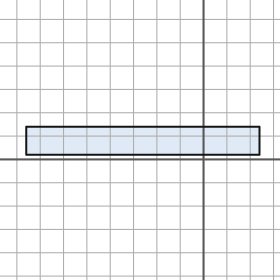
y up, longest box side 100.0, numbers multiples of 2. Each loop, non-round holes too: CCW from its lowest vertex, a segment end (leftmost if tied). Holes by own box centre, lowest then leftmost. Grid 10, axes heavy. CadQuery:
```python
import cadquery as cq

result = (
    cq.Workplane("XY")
    .moveTo(-76.0, 2.0)
    .lineTo(24.0, 2.0)
    .lineTo(24.0, 14.0)
    .lineTo(-76.0, 14.0)
    .close()
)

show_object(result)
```